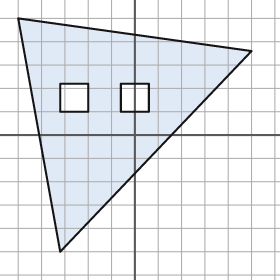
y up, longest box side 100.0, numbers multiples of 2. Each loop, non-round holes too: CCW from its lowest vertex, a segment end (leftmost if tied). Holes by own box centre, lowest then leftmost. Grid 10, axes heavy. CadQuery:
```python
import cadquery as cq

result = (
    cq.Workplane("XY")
    .moveTo(-32.0, -50.0)
    .lineTo(50.0, 36.0)
    .lineTo(-50.0, 50.0)
    .close()
    .moveTo(-32.0, 10.0)
    .lineTo(-20.0, 10.0)
    .lineTo(-20.0, 22.0)
    .lineTo(-32.0, 22.0)
    .close()
    .moveTo(-6.0, 10.0)
    .lineTo(6.0, 10.0)
    .lineTo(6.0, 22.0)
    .lineTo(-6.0, 22.0)
    .close()
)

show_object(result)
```